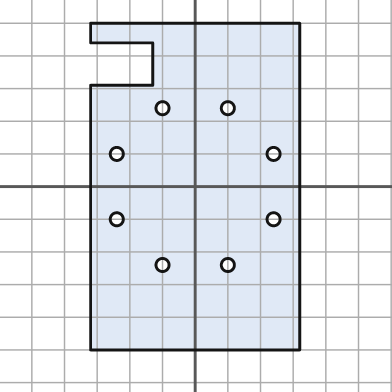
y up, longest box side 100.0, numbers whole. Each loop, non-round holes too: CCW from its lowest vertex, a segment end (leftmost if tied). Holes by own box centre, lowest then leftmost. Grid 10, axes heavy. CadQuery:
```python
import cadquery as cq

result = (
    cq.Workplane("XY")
    .moveTo(-32.0, -50.0)
    .lineTo(32.0, -50.0)
    .lineTo(32.0, 50.0)
    .lineTo(-32.0, 50.0)
    .lineTo(-32.0, 44.0)
    .lineTo(-13.0, 44.0)
    .lineTo(-13.0, 31.0)
    .lineTo(-32.0, 31.0)
    .close()
    .moveTo(-10.0, -24.0)
    .circle(2.0)
    .moveTo(10.0, -24.0)
    .circle(2.0)
    .moveTo(-24.0, -10.0)
    .circle(2.0)
    .moveTo(24.0, -10.0)
    .circle(2.0)
    .moveTo(-24.0, 10.0)
    .circle(2.0)
    .moveTo(24.0, 10.0)
    .circle(2.0)
    .moveTo(-10.0, 24.0)
    .circle(2.0)
    .moveTo(10.0, 24.0)
    .circle(2.0)
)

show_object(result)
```